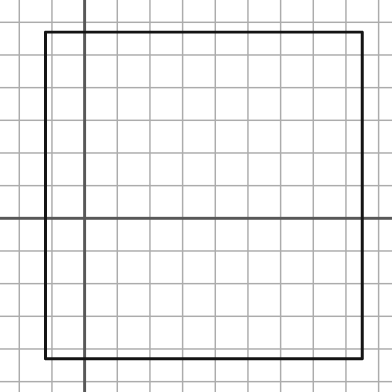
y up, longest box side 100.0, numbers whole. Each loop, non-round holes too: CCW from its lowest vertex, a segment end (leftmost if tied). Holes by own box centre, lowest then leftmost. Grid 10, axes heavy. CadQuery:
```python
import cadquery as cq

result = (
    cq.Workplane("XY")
    .moveTo(-12.0, -43.0)
    .lineTo(85.0, -43.0)
    .lineTo(85.0, 57.0)
    .lineTo(-12.0, 57.0)
    .close()
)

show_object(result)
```